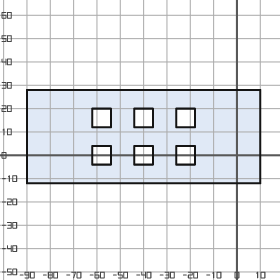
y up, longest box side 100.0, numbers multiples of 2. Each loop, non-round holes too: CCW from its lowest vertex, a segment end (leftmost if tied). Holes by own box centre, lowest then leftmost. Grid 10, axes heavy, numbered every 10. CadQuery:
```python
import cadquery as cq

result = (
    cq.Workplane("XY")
    .moveTo(-90.0, -12.0)
    .lineTo(10.0, -12.0)
    .lineTo(10.0, 28.0)
    .lineTo(-90.0, 28.0)
    .close()
    .moveTo(-62.0, -4.0)
    .lineTo(-54.0, -4.0)
    .lineTo(-54.0, 4.0)
    .lineTo(-62.0, 4.0)
    .close()
    .moveTo(-44.0, -4.0)
    .lineTo(-36.0, -4.0)
    .lineTo(-36.0, 4.0)
    .lineTo(-44.0, 4.0)
    .close()
    .moveTo(-26.0, -4.0)
    .lineTo(-18.0, -4.0)
    .lineTo(-18.0, 4.0)
    .lineTo(-26.0, 4.0)
    .close()
    .moveTo(-62.0, 12.0)
    .lineTo(-54.0, 12.0)
    .lineTo(-54.0, 20.0)
    .lineTo(-62.0, 20.0)
    .close()
    .moveTo(-44.0, 12.0)
    .lineTo(-36.0, 12.0)
    .lineTo(-36.0, 20.0)
    .lineTo(-44.0, 20.0)
    .close()
    .moveTo(-26.0, 12.0)
    .lineTo(-18.0, 12.0)
    .lineTo(-18.0, 20.0)
    .lineTo(-26.0, 20.0)
    .close()
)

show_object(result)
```